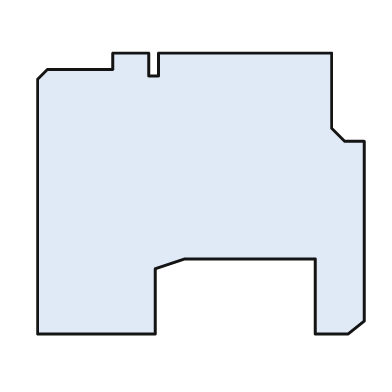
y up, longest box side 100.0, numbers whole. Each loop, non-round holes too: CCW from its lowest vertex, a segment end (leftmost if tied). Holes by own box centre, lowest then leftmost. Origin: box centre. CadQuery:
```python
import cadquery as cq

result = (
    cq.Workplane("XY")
    .moveTo(-50.0, -43.0)
    .lineTo(-14.0, -43.0)
    .lineTo(-14.0, -23.0)
    .lineTo(-5.0, -20.0)
    .lineTo(35.0, -20.0)
    .lineTo(35.0, -43.0)
    .lineTo(45.0, -43.0)
    .lineTo(50.0, -39.0)
    .lineTo(50.0, 16.0)
    .lineTo(44.0, 16.0)
    .lineTo(40.0, 20.0)
    .lineTo(40.0, 43.0)
    .lineTo(-13.0, 43.0)
    .lineTo(-13.0, 36.0)
    .lineTo(-16.0, 36.0)
    .lineTo(-16.0, 43.0)
    .lineTo(-27.0, 43.0)
    .lineTo(-27.0, 38.0)
    .lineTo(-47.0, 38.0)
    .lineTo(-50.0, 35.0)
    .close()
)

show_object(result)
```